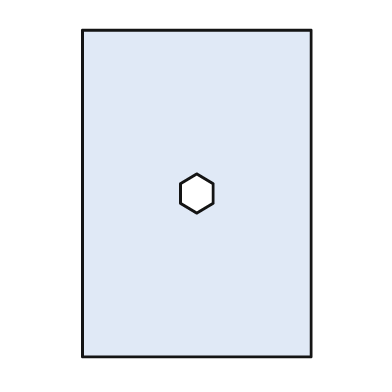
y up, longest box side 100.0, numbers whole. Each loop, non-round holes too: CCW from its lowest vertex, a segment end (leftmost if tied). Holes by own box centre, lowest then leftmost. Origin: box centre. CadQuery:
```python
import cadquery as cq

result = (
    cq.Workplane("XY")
    .moveTo(-35.0, -50.0)
    .lineTo(35.0, -50.0)
    .lineTo(35.0, 50.0)
    .lineTo(-35.0, 50.0)
    .close()
    .moveTo(0.0, -6.0)
    .lineTo(5.0, -3.0)
    .lineTo(5.0, 3.0)
    .lineTo(0.0, 6.0)
    .lineTo(-5.0, 3.0)
    .lineTo(-5.0, -3.0)
    .close()
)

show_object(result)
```